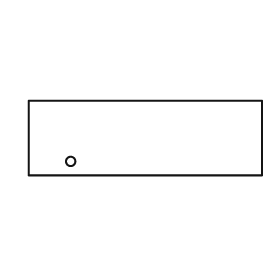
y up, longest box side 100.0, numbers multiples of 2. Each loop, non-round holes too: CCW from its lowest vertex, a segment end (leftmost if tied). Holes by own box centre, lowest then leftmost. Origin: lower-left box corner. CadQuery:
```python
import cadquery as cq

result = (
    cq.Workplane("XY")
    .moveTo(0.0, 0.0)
    .lineTo(100.0, 0.0)
    .lineTo(100.0, 32.0)
    .lineTo(0.0, 32.0)
    .close()
    .moveTo(18.0, 6.0)
    .circle(2.0)
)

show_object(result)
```